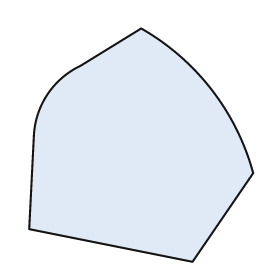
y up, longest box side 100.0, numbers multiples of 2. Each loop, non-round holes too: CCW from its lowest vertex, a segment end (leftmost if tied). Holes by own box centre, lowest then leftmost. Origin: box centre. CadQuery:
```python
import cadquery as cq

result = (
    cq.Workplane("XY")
    .moveTo(22.0, -50.0)
    .lineTo(48.0, -12.0)
    .threePointArc((30.0, 24.0), (0.0, 50.0))
    .lineTo(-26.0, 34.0)
    .threePointArc((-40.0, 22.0), (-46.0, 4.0))
    .lineTo(-48.0, -36.0)
    .close()
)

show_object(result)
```